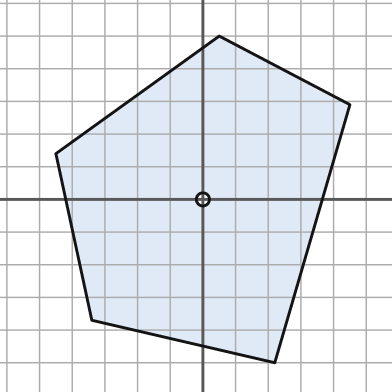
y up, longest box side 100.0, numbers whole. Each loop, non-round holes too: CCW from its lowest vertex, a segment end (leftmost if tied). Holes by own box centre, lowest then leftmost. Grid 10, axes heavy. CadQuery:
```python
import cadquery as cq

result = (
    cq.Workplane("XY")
    .moveTo(22.0, -50.0)
    .lineTo(45.0, 29.0)
    .lineTo(5.0, 50.0)
    .lineTo(-45.0, 14.0)
    .lineTo(-34.0, -37.0)
    .close()
    .moveTo(0.0, 0.0)
    .circle(2.0)
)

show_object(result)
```